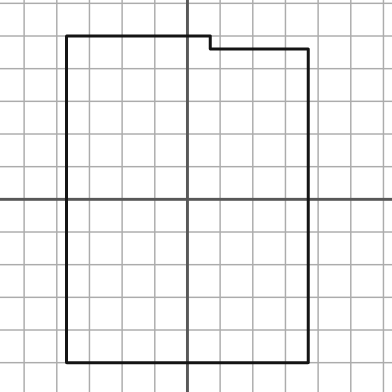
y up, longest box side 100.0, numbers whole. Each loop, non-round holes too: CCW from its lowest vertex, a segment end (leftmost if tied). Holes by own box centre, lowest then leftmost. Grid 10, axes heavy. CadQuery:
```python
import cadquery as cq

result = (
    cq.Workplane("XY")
    .moveTo(-37.0, -50.0)
    .lineTo(37.0, -50.0)
    .lineTo(37.0, 46.0)
    .lineTo(7.0, 46.0)
    .lineTo(7.0, 50.0)
    .lineTo(-37.0, 50.0)
    .close()
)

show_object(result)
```